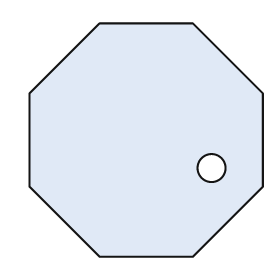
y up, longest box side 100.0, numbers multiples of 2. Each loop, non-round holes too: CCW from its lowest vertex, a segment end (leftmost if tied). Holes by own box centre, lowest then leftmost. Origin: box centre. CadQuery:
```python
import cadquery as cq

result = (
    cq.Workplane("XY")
    .moveTo(-20.0, -50.0)
    .lineTo(20.0, -50.0)
    .lineTo(50.0, -20.0)
    .lineTo(50.0, 20.0)
    .lineTo(20.0, 50.0)
    .lineTo(-20.0, 50.0)
    .lineTo(-50.0, 20.0)
    .lineTo(-50.0, -20.0)
    .close()
    .moveTo(28.0, -12.0)
    .circle(6.0)
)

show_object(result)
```